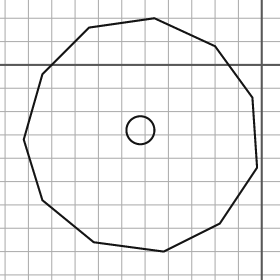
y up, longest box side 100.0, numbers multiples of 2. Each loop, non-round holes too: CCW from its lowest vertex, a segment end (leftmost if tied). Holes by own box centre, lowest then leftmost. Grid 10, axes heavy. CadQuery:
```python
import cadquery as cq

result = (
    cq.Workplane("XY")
    .moveTo(-42.0, -80.0)
    .lineTo(-18.0, -68.0)
    .lineTo(-2.0, -44.0)
    .lineTo(-4.0, -14.0)
    .lineTo(-20.0, 8.0)
    .lineTo(-46.0, 20.0)
    .lineTo(-74.0, 16.0)
    .lineTo(-94.0, -4.0)
    .lineTo(-102.0, -32.0)
    .lineTo(-94.0, -58.0)
    .lineTo(-72.0, -76.0)
    .close()
    .moveTo(-52.0, -28.0)
    .circle(6.0)
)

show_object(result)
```